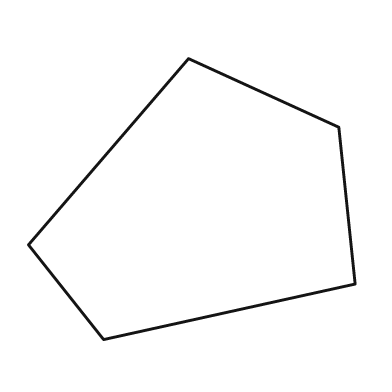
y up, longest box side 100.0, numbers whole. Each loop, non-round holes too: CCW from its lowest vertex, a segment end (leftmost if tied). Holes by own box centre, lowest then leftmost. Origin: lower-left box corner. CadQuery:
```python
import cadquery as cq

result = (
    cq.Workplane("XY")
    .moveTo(23.0, 0.0)
    .lineTo(100.0, 17.0)
    .lineTo(95.0, 65.0)
    .lineTo(49.0, 86.0)
    .lineTo(0.0, 29.0)
    .close()
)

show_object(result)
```